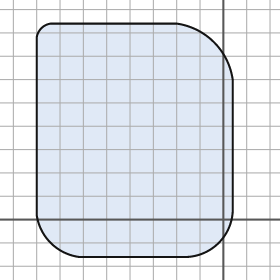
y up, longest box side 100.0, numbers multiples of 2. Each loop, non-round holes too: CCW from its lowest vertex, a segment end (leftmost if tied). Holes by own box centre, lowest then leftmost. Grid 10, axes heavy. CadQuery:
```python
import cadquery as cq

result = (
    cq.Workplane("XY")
    .moveTo(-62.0, -16.0)
    .lineTo(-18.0, -16.0)
    .threePointArc((-2.0, -10.0), (4.0, 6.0))
    .lineTo(4.0, 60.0)
    .threePointArc((-4.0, 76.0), (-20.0, 84.0))
    .lineTo(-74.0, 84.0)
    .threePointArc((-78.0, 82.0), (-80.0, 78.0))
    .lineTo(-80.0, 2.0)
    .threePointArc((-74.0, -10.0), (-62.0, -16.0))
    .close()
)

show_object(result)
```